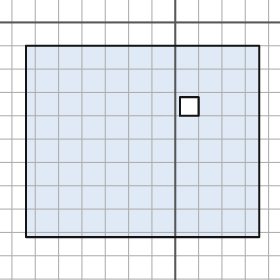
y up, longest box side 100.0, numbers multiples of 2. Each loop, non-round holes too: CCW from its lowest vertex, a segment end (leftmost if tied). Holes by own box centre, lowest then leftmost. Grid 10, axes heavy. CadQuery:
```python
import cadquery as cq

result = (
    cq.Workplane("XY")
    .moveTo(-64.0, -92.0)
    .lineTo(36.0, -92.0)
    .lineTo(36.0, -10.0)
    .lineTo(-64.0, -10.0)
    .close()
    .moveTo(2.0, -40.0)
    .lineTo(10.0, -40.0)
    .lineTo(10.0, -32.0)
    .lineTo(2.0, -32.0)
    .close()
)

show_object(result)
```